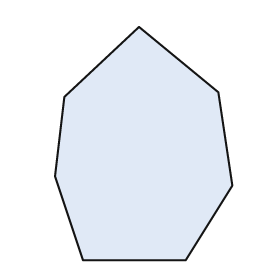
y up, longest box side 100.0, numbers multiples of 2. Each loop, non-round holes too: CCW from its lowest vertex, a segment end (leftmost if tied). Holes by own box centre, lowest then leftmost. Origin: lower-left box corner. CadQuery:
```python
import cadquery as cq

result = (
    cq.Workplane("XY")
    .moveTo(12.0, 0.0)
    .lineTo(56.0, 0.0)
    .lineTo(76.0, 32.0)
    .lineTo(70.0, 72.0)
    .lineTo(36.0, 100.0)
    .lineTo(4.0, 70.0)
    .lineTo(0.0, 36.0)
    .close()
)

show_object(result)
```